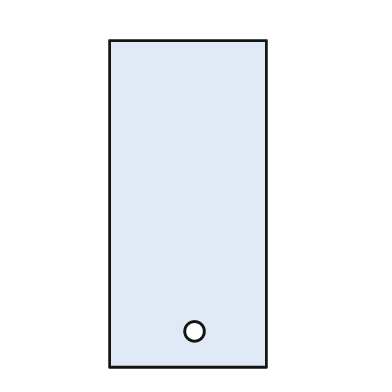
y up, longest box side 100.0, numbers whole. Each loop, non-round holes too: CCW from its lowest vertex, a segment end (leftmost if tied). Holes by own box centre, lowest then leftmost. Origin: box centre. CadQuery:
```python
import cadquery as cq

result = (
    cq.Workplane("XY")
    .moveTo(-24.0, -50.0)
    .lineTo(24.0, -50.0)
    .lineTo(24.0, 50.0)
    .lineTo(-24.0, 50.0)
    .close()
    .moveTo(2.0, -39.0)
    .circle(3.0)
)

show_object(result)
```